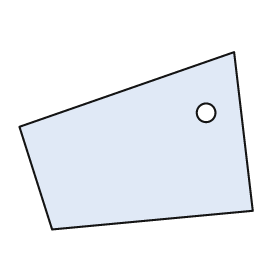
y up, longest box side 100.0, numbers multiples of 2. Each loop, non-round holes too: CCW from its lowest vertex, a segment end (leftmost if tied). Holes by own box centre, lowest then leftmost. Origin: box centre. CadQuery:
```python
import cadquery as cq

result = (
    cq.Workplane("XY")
    .moveTo(-36.0, -38.0)
    .lineTo(50.0, -30.0)
    .lineTo(42.0, 38.0)
    .lineTo(-50.0, 6.0)
    .close()
    .moveTo(30.0, 12.0)
    .circle(4.0)
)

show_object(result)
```